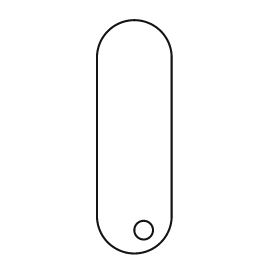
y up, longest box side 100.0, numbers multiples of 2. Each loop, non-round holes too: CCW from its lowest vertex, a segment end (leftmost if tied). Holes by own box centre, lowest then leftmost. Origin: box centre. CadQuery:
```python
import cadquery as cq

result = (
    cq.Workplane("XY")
    .moveTo(-16.0, -34.0)
    .threePointArc((0.0, -50.0), (16.0, -34.0))
    .lineTo(16.0, 34.0)
    .threePointArc((0.0, 50.0), (-16.0, 34.0))
    .close()
    .moveTo(4.0, -40.0)
    .circle(4.0)
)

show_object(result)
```